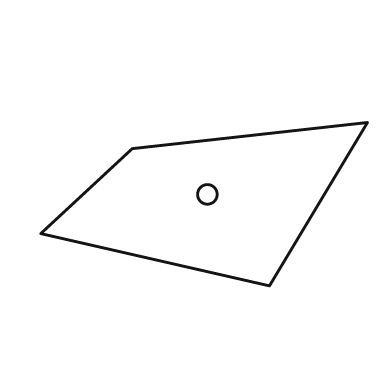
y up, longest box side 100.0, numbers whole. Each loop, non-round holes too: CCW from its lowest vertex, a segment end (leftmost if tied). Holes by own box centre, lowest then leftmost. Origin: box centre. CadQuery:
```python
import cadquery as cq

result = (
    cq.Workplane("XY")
    .moveTo(20.0, -25.0)
    .lineTo(50.0, 25.0)
    .lineTo(-22.0, 17.0)
    .lineTo(-50.0, -9.0)
    .close()
    .moveTo(1.0, 3.0)
    .circle(3.0)
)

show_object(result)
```